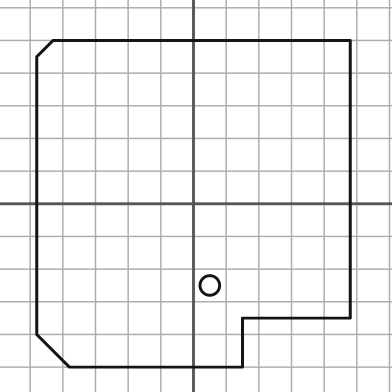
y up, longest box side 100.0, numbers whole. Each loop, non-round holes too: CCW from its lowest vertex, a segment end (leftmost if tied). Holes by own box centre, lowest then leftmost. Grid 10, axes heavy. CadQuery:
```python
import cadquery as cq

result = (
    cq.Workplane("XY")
    .moveTo(-38.0, -50.0)
    .lineTo(15.0, -50.0)
    .lineTo(15.0, -35.0)
    .lineTo(48.0, -35.0)
    .lineTo(48.0, 50.0)
    .lineTo(-43.0, 50.0)
    .lineTo(-48.0, 45.0)
    .lineTo(-48.0, -40.0)
    .close()
    .moveTo(5.0, -25.0)
    .circle(3.0)
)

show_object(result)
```